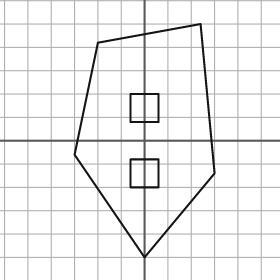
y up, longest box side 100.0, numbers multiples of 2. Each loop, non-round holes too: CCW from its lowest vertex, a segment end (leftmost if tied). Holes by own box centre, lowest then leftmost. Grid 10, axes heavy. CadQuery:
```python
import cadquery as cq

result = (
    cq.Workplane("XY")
    .moveTo(0.0, -50.0)
    .lineTo(30.0, -14.0)
    .lineTo(24.0, 50.0)
    .lineTo(-20.0, 42.0)
    .lineTo(-30.0, -6.0)
    .close()
    .moveTo(-6.0, -20.0)
    .lineTo(6.0, -20.0)
    .lineTo(6.0, -8.0)
    .lineTo(-6.0, -8.0)
    .close()
    .moveTo(-6.0, 8.0)
    .lineTo(6.0, 8.0)
    .lineTo(6.0, 20.0)
    .lineTo(-6.0, 20.0)
    .close()
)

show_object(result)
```